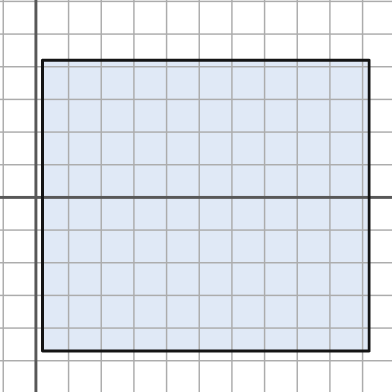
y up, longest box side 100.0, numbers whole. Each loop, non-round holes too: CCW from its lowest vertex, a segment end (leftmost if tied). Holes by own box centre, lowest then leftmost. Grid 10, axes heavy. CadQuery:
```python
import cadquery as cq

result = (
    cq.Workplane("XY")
    .moveTo(2.0, -47.0)
    .lineTo(102.0, -47.0)
    .lineTo(102.0, 42.0)
    .lineTo(2.0, 42.0)
    .close()
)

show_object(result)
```